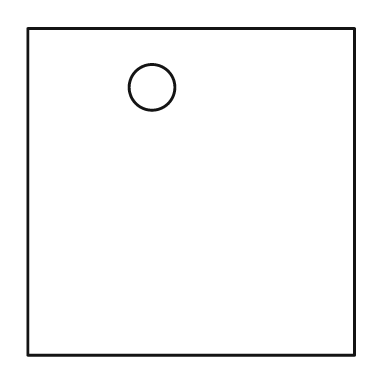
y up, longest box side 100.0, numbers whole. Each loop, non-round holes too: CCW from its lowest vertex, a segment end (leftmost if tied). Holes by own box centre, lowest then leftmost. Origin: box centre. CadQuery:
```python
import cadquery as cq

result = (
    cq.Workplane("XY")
    .moveTo(-50.0, -50.0)
    .lineTo(50.0, -50.0)
    .lineTo(50.0, 50.0)
    .lineTo(-50.0, 50.0)
    .close()
    .moveTo(-12.0, 32.0)
    .circle(7.0)
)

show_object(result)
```